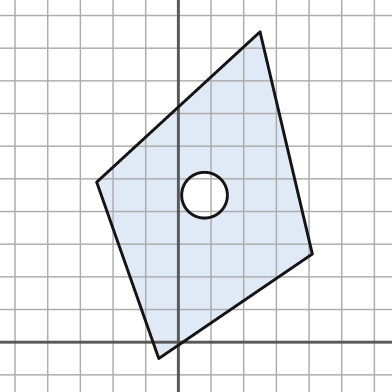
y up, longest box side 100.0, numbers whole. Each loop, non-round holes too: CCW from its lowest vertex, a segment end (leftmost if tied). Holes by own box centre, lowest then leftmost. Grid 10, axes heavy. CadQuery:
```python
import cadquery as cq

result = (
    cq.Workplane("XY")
    .moveTo(-6.0, -5.0)
    .lineTo(41.0, 27.0)
    .lineTo(25.0, 95.0)
    .lineTo(-25.0, 49.0)
    .close()
    .moveTo(8.0, 45.0)
    .circle(7.0)
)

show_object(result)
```